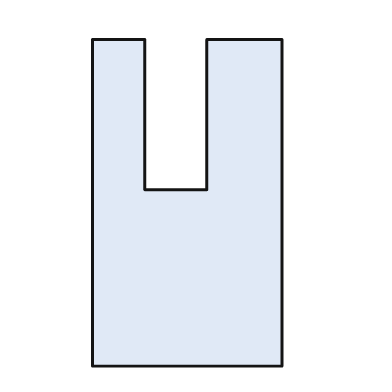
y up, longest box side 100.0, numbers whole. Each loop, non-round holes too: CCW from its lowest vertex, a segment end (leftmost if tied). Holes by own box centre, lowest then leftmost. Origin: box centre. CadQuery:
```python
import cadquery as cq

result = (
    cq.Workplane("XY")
    .moveTo(-29.0, -50.0)
    .lineTo(29.0, -50.0)
    .lineTo(29.0, 50.0)
    .lineTo(6.0, 50.0)
    .lineTo(6.0, 4.0)
    .lineTo(-13.0, 4.0)
    .lineTo(-13.0, 50.0)
    .lineTo(-29.0, 50.0)
    .close()
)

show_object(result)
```